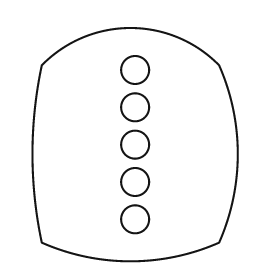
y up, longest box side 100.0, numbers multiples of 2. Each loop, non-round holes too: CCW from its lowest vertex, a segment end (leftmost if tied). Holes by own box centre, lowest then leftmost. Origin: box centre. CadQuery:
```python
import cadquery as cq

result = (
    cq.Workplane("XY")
    .moveTo(-40.0, -42.0)
    .threePointArc((-2.0, -50.0), (36.0, -42.0))
    .threePointArc((44.0, -4.0), (36.0, 34.0))
    .threePointArc((-2.0, 50.0), (-40.0, 34.0))
    .threePointArc((-44.0, -4.0), (-40.0, -42.0))
    .close()
    .moveTo(0.0, -32.0)
    .circle(6.0)
    .moveTo(0.0, -16.0)
    .circle(6.0)
    .moveTo(0.0, 0.0)
    .circle(6.0)
    .moveTo(0.0, 16.0)
    .circle(6.0)
    .moveTo(0.0, 32.0)
    .circle(6.0)
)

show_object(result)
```